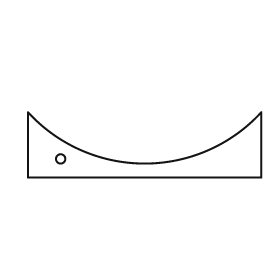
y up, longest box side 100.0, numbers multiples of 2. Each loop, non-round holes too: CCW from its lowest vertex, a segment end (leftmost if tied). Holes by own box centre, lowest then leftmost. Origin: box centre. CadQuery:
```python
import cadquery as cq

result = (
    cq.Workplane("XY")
    .moveTo(-50.0, -14.0)
    .lineTo(50.0, -14.0)
    .lineTo(50.0, 14.0)
    .threePointArc((0.0, -8.0), (-50.0, 14.0))
    .close()
    .moveTo(-36.0, -6.0)
    .circle(2.0)
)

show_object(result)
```